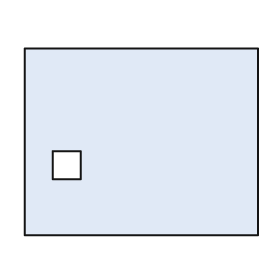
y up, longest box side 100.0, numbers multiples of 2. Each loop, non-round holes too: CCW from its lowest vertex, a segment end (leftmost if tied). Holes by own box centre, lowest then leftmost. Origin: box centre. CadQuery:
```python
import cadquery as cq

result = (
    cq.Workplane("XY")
    .moveTo(-50.0, -40.0)
    .lineTo(50.0, -40.0)
    .lineTo(50.0, 40.0)
    .lineTo(-50.0, 40.0)
    .close()
    .moveTo(-38.0, -16.0)
    .lineTo(-26.0, -16.0)
    .lineTo(-26.0, -4.0)
    .lineTo(-38.0, -4.0)
    .close()
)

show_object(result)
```